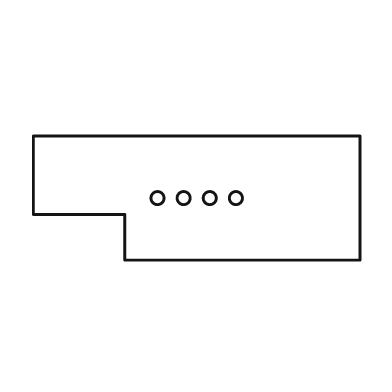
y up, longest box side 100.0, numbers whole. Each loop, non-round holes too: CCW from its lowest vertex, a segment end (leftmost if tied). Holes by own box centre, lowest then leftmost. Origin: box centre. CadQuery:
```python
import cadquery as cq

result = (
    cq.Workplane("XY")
    .moveTo(-22.0, -19.0)
    .lineTo(50.0, -19.0)
    .lineTo(50.0, 19.0)
    .lineTo(-50.0, 19.0)
    .lineTo(-50.0, -5.0)
    .lineTo(-22.0, -5.0)
    .close()
    .moveTo(-12.0, 0.0)
    .circle(2.0)
    .moveTo(-4.0, 0.0)
    .circle(2.0)
    .moveTo(4.0, 0.0)
    .circle(2.0)
    .moveTo(12.0, 0.0)
    .circle(2.0)
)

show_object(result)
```